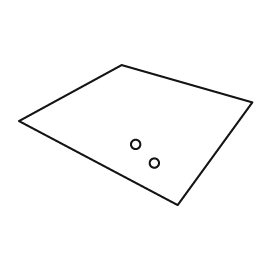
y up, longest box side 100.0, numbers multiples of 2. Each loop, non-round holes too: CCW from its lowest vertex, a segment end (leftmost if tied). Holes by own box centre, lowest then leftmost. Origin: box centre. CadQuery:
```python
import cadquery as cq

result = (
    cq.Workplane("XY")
    .moveTo(18.0, -30.0)
    .lineTo(50.0, 14.0)
    .lineTo(-6.0, 30.0)
    .lineTo(-50.0, 6.0)
    .close()
    .moveTo(8.0, -12.0)
    .circle(2.0)
    .moveTo(0.0, -4.0)
    .circle(2.0)
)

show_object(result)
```